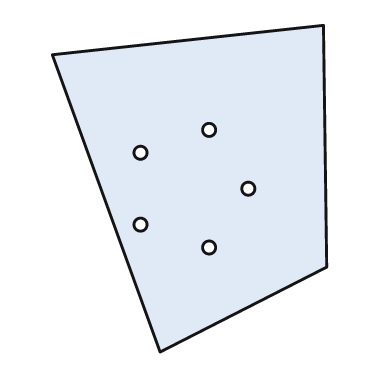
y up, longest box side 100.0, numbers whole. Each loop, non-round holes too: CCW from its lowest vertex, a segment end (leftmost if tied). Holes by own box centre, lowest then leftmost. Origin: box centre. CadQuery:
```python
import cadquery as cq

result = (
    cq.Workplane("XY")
    .moveTo(-9.0, -50.0)
    .lineTo(42.0, -24.0)
    .lineTo(41.0, 50.0)
    .lineTo(-42.0, 41.0)
    .close()
    .moveTo(6.0, -18.0)
    .circle(2.0)
    .moveTo(-15.0, -11.0)
    .circle(2.0)
    .moveTo(18.0, 0.0)
    .circle(2.0)
    .moveTo(-15.0, 11.0)
    .circle(2.0)
    .moveTo(6.0, 18.0)
    .circle(2.0)
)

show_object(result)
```